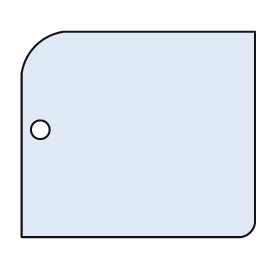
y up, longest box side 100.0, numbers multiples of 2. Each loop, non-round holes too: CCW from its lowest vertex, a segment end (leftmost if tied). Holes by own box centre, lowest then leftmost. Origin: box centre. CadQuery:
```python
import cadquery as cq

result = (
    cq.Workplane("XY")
    .moveTo(-50.0, -44.0)
    .lineTo(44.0, -44.0)
    .threePointArc((48.0, -42.0), (50.0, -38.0))
    .lineTo(50.0, 44.0)
    .lineTo(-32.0, 44.0)
    .threePointArc((-44.0, 38.0), (-50.0, 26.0))
    .close()
    .moveTo(-42.0, 2.0)
    .circle(4.0)
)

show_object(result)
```